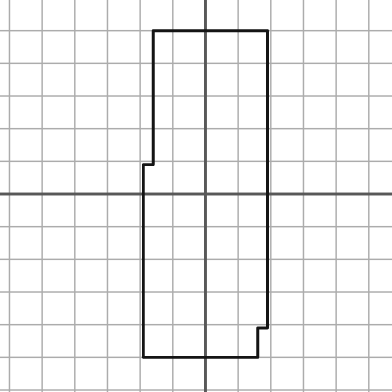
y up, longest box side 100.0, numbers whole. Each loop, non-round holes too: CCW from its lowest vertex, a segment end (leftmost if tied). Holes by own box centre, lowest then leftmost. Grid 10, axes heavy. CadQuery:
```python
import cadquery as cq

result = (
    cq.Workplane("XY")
    .moveTo(-19.0, -50.0)
    .lineTo(16.0, -50.0)
    .lineTo(16.0, -41.0)
    .lineTo(19.0, -41.0)
    .lineTo(19.0, 50.0)
    .lineTo(-16.0, 50.0)
    .lineTo(-16.0, 9.0)
    .lineTo(-19.0, 9.0)
    .close()
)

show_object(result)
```